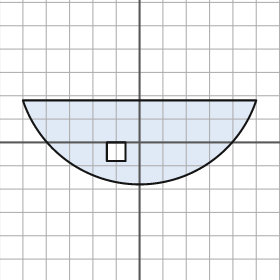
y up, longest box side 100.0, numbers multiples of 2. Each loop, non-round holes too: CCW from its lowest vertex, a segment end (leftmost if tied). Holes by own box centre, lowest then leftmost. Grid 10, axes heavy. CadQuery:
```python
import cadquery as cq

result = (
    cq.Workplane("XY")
    .moveTo(-50.0, 18.0)
    .threePointArc((0.0, -18.0), (50.0, 18.0))
    .close()
    .moveTo(-14.0, -8.0)
    .lineTo(-6.0, -8.0)
    .lineTo(-6.0, 0.0)
    .lineTo(-14.0, 0.0)
    .close()
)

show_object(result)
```